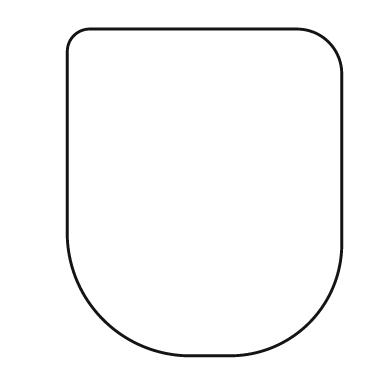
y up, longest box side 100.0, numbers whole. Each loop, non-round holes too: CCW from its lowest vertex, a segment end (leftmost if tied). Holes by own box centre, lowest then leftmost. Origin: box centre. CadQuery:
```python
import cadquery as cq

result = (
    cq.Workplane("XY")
    .moveTo(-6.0, -50.0)
    .lineTo(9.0, -50.0)
    .threePointArc((32.0, -40.0), (42.0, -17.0))
    .lineTo(42.0, 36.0)
    .threePointArc((38.0, 46.0), (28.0, 50.0))
    .lineTo(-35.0, 50.0)
    .threePointArc((-40.0, 48.0), (-42.0, 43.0))
    .lineTo(-42.0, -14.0)
    .threePointArc((-31.0, -39.0), (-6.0, -50.0))
    .close()
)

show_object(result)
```